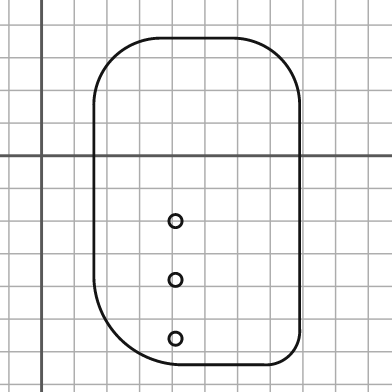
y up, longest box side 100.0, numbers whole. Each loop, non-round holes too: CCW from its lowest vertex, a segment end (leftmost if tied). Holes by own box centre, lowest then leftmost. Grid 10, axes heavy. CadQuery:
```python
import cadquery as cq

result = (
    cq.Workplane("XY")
    .moveTo(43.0, -64.0)
    .lineTo(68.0, -64.0)
    .threePointArc((76.0, -61.0), (79.0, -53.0))
    .lineTo(79.0, 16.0)
    .threePointArc((73.0, 30.0), (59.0, 36.0))
    .lineTo(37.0, 36.0)
    .threePointArc((22.0, 30.0), (16.0, 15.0))
    .lineTo(16.0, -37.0)
    .threePointArc((24.0, -56.0), (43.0, -64.0))
    .close()
    .moveTo(41.0, -56.0)
    .circle(2.0)
    .moveTo(41.0, -38.0)
    .circle(2.0)
    .moveTo(41.0, -20.0)
    .circle(2.0)
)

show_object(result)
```